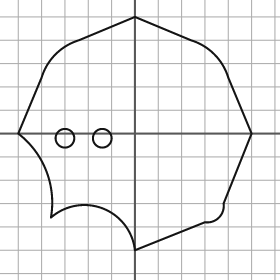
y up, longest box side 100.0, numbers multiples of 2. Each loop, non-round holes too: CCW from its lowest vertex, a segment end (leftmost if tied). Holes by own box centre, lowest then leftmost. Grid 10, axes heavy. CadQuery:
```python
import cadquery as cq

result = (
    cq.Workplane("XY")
    .moveTo(0.0, -50.0)
    .lineTo(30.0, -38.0)
    .threePointArc((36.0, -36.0), (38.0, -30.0))
    .lineTo(50.0, 0.0)
    .lineTo(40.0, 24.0)
    .threePointArc((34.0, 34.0), (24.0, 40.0))
    .lineTo(0.0, 50.0)
    .lineTo(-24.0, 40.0)
    .threePointArc((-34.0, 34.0), (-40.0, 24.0))
    .lineTo(-50.0, 0.0)
    .threePointArc((-38.0, -16.0), (-36.0, -36.0))
    .threePointArc((-14.0, -32.0), (0.0, -50.0))
    .close()
    .moveTo(-30.0, -2.0)
    .circle(4.0)
    .moveTo(-14.0, -2.0)
    .circle(4.0)
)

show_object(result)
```